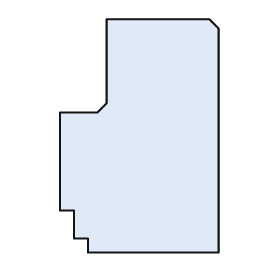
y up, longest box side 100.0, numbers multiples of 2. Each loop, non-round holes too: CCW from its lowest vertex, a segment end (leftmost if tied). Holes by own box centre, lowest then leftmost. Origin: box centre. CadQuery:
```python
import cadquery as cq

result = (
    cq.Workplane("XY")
    .moveTo(-22.0, -50.0)
    .lineTo(34.0, -50.0)
    .lineTo(34.0, 46.0)
    .lineTo(30.0, 50.0)
    .lineTo(-14.0, 50.0)
    .lineTo(-14.0, 14.0)
    .lineTo(-18.0, 10.0)
    .lineTo(-34.0, 10.0)
    .lineTo(-34.0, -32.0)
    .lineTo(-28.0, -32.0)
    .lineTo(-28.0, -44.0)
    .lineTo(-22.0, -44.0)
    .close()
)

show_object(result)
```